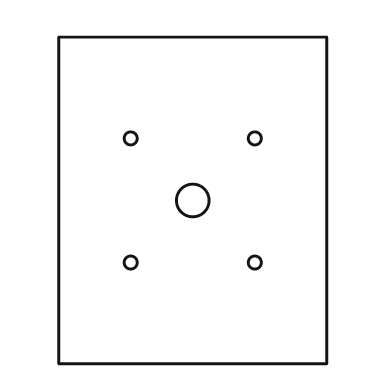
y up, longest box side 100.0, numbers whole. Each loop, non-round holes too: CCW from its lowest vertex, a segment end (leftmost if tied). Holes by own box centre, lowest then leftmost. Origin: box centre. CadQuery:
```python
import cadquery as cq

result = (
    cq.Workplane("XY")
    .moveTo(-41.0, -50.0)
    .lineTo(41.0, -50.0)
    .lineTo(41.0, 50.0)
    .lineTo(-41.0, 50.0)
    .close()
    .moveTo(-19.0, -19.0)
    .circle(2.0)
    .moveTo(19.0, -19.0)
    .circle(2.0)
    .moveTo(0.0, 0.0)
    .circle(5.0)
    .moveTo(-19.0, 19.0)
    .circle(2.0)
    .moveTo(19.0, 19.0)
    .circle(2.0)
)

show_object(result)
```